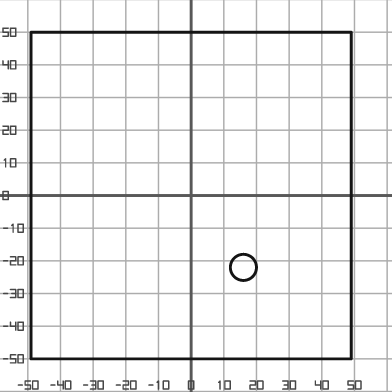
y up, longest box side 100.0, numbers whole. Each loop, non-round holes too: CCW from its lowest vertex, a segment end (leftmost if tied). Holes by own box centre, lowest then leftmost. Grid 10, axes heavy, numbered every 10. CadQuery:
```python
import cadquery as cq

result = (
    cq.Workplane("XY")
    .moveTo(-49.0, -50.0)
    .lineTo(49.0, -50.0)
    .lineTo(49.0, 50.0)
    .lineTo(-49.0, 50.0)
    .close()
    .moveTo(16.0, -22.0)
    .circle(4.0)
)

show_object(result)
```